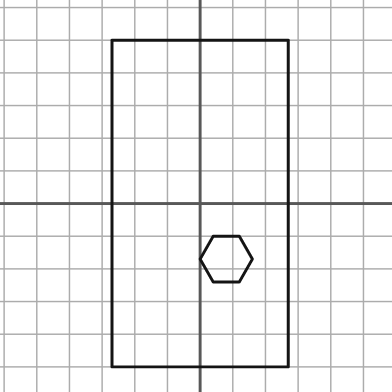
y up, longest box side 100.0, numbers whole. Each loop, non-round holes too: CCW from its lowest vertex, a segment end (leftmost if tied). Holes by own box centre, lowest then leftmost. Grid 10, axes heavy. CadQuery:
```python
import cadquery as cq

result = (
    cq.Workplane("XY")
    .moveTo(-27.0, -50.0)
    .lineTo(27.0, -50.0)
    .lineTo(27.0, 50.0)
    .lineTo(-27.0, 50.0)
    .close()
    .moveTo(4.0, -24.0)
    .lineTo(12.0, -24.0)
    .lineTo(16.0, -17.0)
    .lineTo(12.0, -10.0)
    .lineTo(4.0, -10.0)
    .lineTo(0.0, -17.0)
    .close()
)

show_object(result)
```